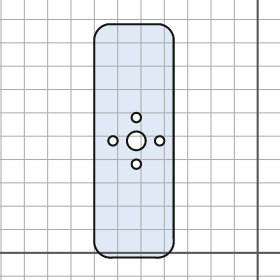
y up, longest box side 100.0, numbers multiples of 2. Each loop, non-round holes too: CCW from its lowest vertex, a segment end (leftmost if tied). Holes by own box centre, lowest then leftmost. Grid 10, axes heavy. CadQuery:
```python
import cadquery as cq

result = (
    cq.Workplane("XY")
    .moveTo(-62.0, -2.0)
    .lineTo(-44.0, -2.0)
    .threePointArc((-38.0, 0.0), (-36.0, 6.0))
    .lineTo(-36.0, 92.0)
    .threePointArc((-38.0, 96.0), (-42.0, 98.0))
    .lineTo(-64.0, 98.0)
    .threePointArc((-68.0, 96.0), (-70.0, 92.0))
    .lineTo(-70.0, 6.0)
    .threePointArc((-68.0, 0.0), (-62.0, -2.0))
    .close()
    .moveTo(-52.0, 38.0)
    .circle(2.0)
    .moveTo(-62.0, 48.0)
    .circle(2.0)
    .moveTo(-52.0, 48.0)
    .circle(4.0)
    .moveTo(-42.0, 48.0)
    .circle(2.0)
    .moveTo(-52.0, 58.0)
    .circle(2.0)
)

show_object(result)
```